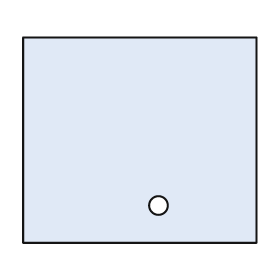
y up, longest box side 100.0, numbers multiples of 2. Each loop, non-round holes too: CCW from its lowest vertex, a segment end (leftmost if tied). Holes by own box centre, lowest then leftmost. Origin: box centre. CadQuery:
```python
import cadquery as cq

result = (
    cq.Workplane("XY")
    .moveTo(-50.0, -44.0)
    .lineTo(50.0, -44.0)
    .lineTo(50.0, 44.0)
    .lineTo(-50.0, 44.0)
    .close()
    .moveTo(8.0, -28.0)
    .circle(4.0)
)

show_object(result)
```